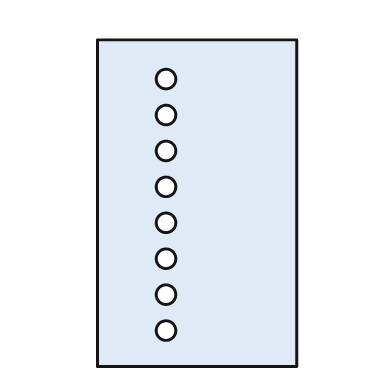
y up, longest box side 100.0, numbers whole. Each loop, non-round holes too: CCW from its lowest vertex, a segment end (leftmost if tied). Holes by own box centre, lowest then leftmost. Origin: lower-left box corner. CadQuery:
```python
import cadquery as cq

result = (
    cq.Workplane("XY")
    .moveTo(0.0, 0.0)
    .lineTo(61.0, 0.0)
    .lineTo(61.0, 100.0)
    .lineTo(0.0, 100.0)
    .close()
    .moveTo(21.0, 11.0)
    .circle(3.0)
    .moveTo(21.0, 22.0)
    .circle(3.0)
    .moveTo(21.0, 33.0)
    .circle(3.0)
    .moveTo(21.0, 44.0)
    .circle(3.0)
    .moveTo(21.0, 55.0)
    .circle(3.0)
    .moveTo(21.0, 66.0)
    .circle(3.0)
    .moveTo(21.0, 77.0)
    .circle(3.0)
    .moveTo(21.0, 88.0)
    .circle(3.0)
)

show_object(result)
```